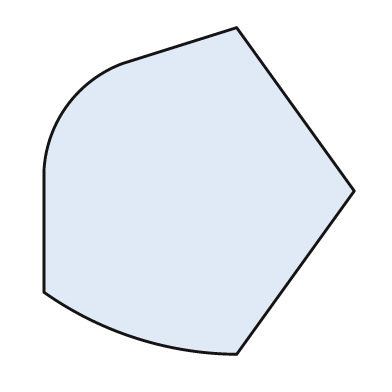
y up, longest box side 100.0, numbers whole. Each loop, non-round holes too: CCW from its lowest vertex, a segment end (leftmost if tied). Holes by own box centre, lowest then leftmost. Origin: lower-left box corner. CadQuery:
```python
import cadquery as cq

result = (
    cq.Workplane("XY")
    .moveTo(59.0, 0.0)
    .lineTo(95.0, 50.0)
    .lineTo(59.0, 100.0)
    .lineTo(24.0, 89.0)
    .threePointArc((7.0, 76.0), (0.0, 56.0))
    .lineTo(0.0, 19.0)
    .threePointArc((28.0, 5.0), (59.0, 0.0))
    .close()
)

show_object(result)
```